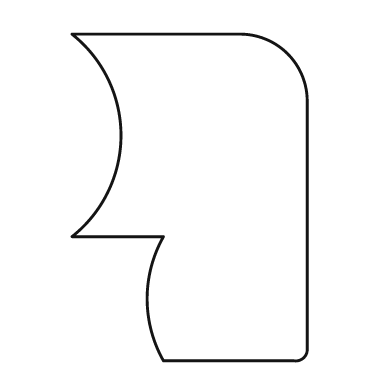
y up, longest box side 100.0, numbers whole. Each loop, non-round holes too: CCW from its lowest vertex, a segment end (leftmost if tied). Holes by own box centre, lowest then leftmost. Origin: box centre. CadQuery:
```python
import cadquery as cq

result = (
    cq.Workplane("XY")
    .moveTo(-8.0, -50.0)
    .lineTo(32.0, -50.0)
    .threePointArc((35.0, -49.0), (36.0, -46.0))
    .lineTo(36.0, 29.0)
    .threePointArc((30.0, 44.0), (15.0, 50.0))
    .lineTo(-36.0, 50.0)
    .threePointArc((-21.0, 19.0), (-36.0, -12.0))
    .lineTo(-8.0, -12.0)
    .threePointArc((-13.0, -31.0), (-8.0, -50.0))
    .close()
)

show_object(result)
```